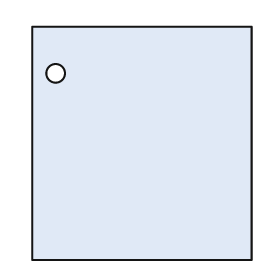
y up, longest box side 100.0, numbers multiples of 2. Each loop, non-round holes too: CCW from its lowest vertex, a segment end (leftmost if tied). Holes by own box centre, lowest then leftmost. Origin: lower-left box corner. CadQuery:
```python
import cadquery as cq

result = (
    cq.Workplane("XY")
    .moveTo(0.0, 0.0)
    .lineTo(94.0, 0.0)
    .lineTo(94.0, 100.0)
    .lineTo(0.0, 100.0)
    .close()
    .moveTo(10.0, 80.0)
    .circle(4.0)
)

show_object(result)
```